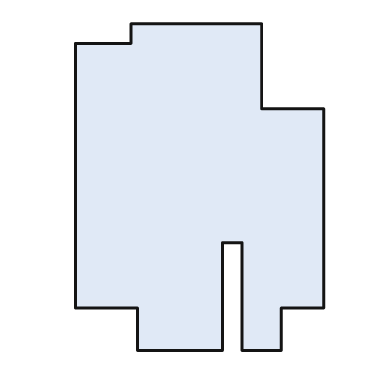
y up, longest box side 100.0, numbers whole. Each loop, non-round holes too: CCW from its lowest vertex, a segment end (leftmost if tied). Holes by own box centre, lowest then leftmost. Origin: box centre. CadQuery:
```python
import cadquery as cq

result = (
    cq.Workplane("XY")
    .moveTo(-19.0, -50.0)
    .lineTo(7.0, -50.0)
    .lineTo(7.0, -17.0)
    .lineTo(13.0, -17.0)
    .lineTo(13.0, -50.0)
    .lineTo(25.0, -50.0)
    .lineTo(25.0, -37.0)
    .lineTo(38.0, -37.0)
    .lineTo(38.0, 24.0)
    .lineTo(19.0, 24.0)
    .lineTo(19.0, 50.0)
    .lineTo(-21.0, 50.0)
    .lineTo(-21.0, 44.0)
    .lineTo(-38.0, 44.0)
    .lineTo(-38.0, -37.0)
    .lineTo(-19.0, -37.0)
    .close()
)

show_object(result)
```